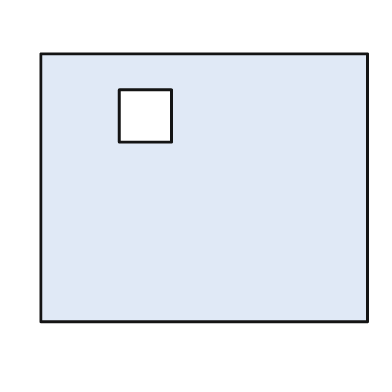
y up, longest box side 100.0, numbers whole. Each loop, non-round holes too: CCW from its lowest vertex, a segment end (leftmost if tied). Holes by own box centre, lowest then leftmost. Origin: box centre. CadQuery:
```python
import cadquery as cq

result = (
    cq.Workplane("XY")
    .moveTo(-50.0, -41.0)
    .lineTo(50.0, -41.0)
    .lineTo(50.0, 41.0)
    .lineTo(-50.0, 41.0)
    .close()
    .moveTo(-26.0, 14.0)
    .lineTo(-10.0, 14.0)
    .lineTo(-10.0, 30.0)
    .lineTo(-26.0, 30.0)
    .close()
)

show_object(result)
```